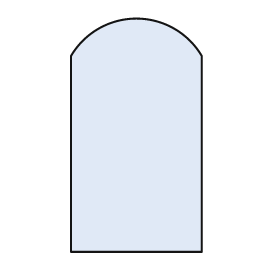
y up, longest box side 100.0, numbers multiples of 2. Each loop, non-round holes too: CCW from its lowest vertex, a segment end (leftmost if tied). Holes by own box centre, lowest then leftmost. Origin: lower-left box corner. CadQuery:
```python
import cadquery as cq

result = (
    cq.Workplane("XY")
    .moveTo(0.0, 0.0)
    .lineTo(56.0, 0.0)
    .lineTo(56.0, 84.0)
    .threePointArc((28.0, 100.0), (0.0, 84.0))
    .close()
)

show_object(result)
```